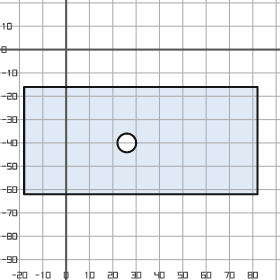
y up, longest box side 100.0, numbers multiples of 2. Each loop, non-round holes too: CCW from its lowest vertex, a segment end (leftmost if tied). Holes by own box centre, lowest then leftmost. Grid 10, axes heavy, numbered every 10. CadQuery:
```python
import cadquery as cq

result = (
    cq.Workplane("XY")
    .moveTo(-18.0, -62.0)
    .lineTo(82.0, -62.0)
    .lineTo(82.0, -16.0)
    .lineTo(-18.0, -16.0)
    .close()
    .moveTo(26.0, -40.0)
    .circle(4.0)
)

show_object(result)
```